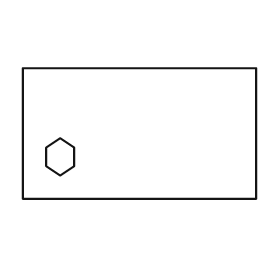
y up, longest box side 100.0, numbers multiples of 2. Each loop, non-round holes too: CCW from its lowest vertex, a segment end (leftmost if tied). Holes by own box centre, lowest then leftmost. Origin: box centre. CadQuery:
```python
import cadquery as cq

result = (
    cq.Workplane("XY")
    .moveTo(-50.0, -28.0)
    .lineTo(50.0, -28.0)
    .lineTo(50.0, 28.0)
    .lineTo(-50.0, 28.0)
    .close()
    .moveTo(-34.0, -18.0)
    .lineTo(-28.0, -14.0)
    .lineTo(-28.0, -6.0)
    .lineTo(-34.0, -2.0)
    .lineTo(-40.0, -6.0)
    .lineTo(-40.0, -14.0)
    .close()
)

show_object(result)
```